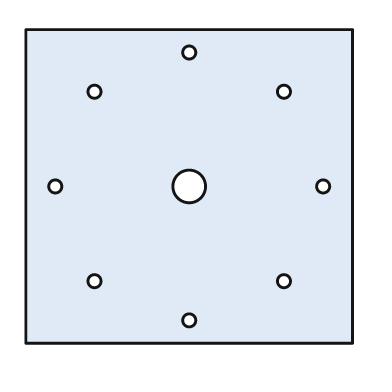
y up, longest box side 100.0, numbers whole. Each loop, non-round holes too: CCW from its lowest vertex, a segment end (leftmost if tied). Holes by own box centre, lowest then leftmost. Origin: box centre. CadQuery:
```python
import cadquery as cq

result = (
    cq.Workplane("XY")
    .moveTo(-50.0, -48.0)
    .lineTo(50.0, -48.0)
    .lineTo(50.0, 48.0)
    .lineTo(-50.0, 48.0)
    .close()
    .moveTo(0.0, -41.0)
    .circle(2.0)
    .moveTo(-29.0, -29.0)
    .circle(2.0)
    .moveTo(29.0, -29.0)
    .circle(2.0)
    .moveTo(-41.0, 0.0)
    .circle(2.0)
    .moveTo(0.0, 0.0)
    .circle(5.0)
    .moveTo(41.0, 0.0)
    .circle(2.0)
    .moveTo(-29.0, 29.0)
    .circle(2.0)
    .moveTo(29.0, 29.0)
    .circle(2.0)
    .moveTo(0.0, 41.0)
    .circle(2.0)
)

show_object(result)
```